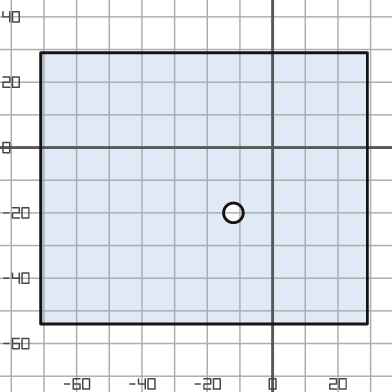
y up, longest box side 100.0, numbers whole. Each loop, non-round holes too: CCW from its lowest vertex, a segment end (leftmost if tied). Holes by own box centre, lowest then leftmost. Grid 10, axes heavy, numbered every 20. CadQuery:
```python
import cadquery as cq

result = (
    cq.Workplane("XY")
    .moveTo(-71.0, -54.0)
    .lineTo(29.0, -54.0)
    .lineTo(29.0, 29.0)
    .lineTo(-71.0, 29.0)
    .close()
    .moveTo(-12.0, -20.0)
    .circle(3.0)
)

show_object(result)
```